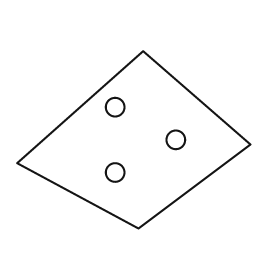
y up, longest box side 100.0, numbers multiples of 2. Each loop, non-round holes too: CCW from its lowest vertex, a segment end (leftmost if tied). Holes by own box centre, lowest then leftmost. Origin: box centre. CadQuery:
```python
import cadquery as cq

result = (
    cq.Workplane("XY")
    .moveTo(2.0, -38.0)
    .lineTo(50.0, -2.0)
    .lineTo(4.0, 38.0)
    .lineTo(-50.0, -10.0)
    .close()
    .moveTo(-8.0, -14.0)
    .circle(4.0)
    .moveTo(18.0, 0.0)
    .circle(4.0)
    .moveTo(-8.0, 14.0)
    .circle(4.0)
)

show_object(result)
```